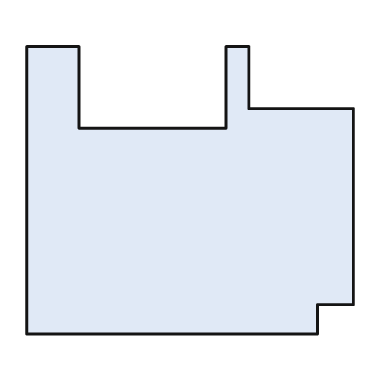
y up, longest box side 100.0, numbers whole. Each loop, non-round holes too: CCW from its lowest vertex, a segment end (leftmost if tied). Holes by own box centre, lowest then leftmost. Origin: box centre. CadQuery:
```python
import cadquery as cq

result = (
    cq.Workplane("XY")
    .moveTo(-50.0, -44.0)
    .lineTo(39.0, -44.0)
    .lineTo(39.0, -35.0)
    .lineTo(50.0, -35.0)
    .lineTo(50.0, 25.0)
    .lineTo(18.0, 25.0)
    .lineTo(18.0, 44.0)
    .lineTo(11.0, 44.0)
    .lineTo(11.0, 19.0)
    .lineTo(-34.0, 19.0)
    .lineTo(-34.0, 44.0)
    .lineTo(-50.0, 44.0)
    .close()
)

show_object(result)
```